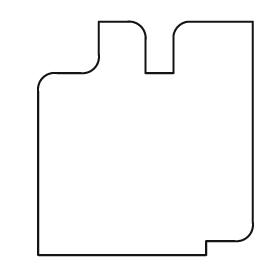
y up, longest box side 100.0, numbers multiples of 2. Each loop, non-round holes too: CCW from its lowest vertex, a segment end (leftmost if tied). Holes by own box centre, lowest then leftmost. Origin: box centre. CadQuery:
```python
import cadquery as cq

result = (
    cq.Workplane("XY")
    .moveTo(-46.0, -50.0)
    .lineTo(26.0, -50.0)
    .lineTo(26.0, -44.0)
    .lineTo(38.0, -44.0)
    .threePointArc((44.0, -42.0), (46.0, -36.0))
    .lineTo(46.0, 50.0)
    .lineTo(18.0, 50.0)
    .threePointArc((14.0, 48.0), (12.0, 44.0))
    .lineTo(12.0, 28.0)
    .lineTo(0.0, 28.0)
    .lineTo(0.0, 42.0)
    .threePointArc((-2.0, 48.0), (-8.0, 50.0))
    .lineTo(-20.0, 50.0)
    .lineTo(-20.0, 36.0)
    .threePointArc((-22.0, 30.0), (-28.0, 28.0))
    .lineTo(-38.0, 28.0)
    .threePointArc((-44.0, 26.0), (-46.0, 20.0))
    .close()
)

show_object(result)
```